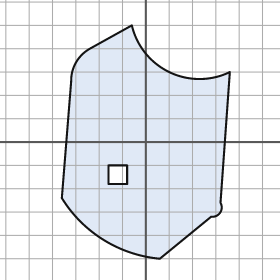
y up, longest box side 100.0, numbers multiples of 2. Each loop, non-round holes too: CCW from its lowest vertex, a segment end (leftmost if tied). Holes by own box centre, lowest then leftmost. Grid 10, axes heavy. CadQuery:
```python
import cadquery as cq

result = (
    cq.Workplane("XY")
    .moveTo(6.0, -50.0)
    .lineTo(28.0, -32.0)
    .threePointArc((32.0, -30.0), (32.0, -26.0))
    .lineTo(36.0, 30.0)
    .threePointArc((10.0, 30.0), (-6.0, 50.0))
    .lineTo(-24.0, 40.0)
    .threePointArc((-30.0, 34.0), (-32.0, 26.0))
    .lineTo(-36.0, -24.0)
    .threePointArc((-18.0, -42.0), (6.0, -50.0))
    .close()
    .moveTo(-16.0, -18.0)
    .lineTo(-8.0, -18.0)
    .lineTo(-8.0, -10.0)
    .lineTo(-16.0, -10.0)
    .close()
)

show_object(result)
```